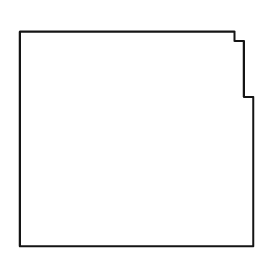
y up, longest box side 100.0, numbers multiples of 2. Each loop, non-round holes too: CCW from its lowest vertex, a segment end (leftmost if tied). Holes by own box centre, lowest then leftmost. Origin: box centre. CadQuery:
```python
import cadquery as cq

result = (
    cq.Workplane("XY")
    .moveTo(-50.0, -46.0)
    .lineTo(50.0, -46.0)
    .lineTo(50.0, 18.0)
    .lineTo(46.0, 18.0)
    .lineTo(46.0, 42.0)
    .lineTo(42.0, 42.0)
    .lineTo(42.0, 46.0)
    .lineTo(-50.0, 46.0)
    .close()
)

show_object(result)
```